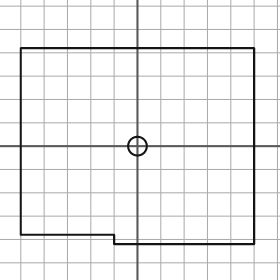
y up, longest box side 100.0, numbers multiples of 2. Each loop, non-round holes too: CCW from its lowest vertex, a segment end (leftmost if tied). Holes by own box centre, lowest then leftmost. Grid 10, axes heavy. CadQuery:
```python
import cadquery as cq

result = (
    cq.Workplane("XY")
    .moveTo(-10.0, -42.0)
    .lineTo(50.0, -42.0)
    .lineTo(50.0, 42.0)
    .lineTo(-50.0, 42.0)
    .lineTo(-50.0, -38.0)
    .lineTo(-10.0, -38.0)
    .close()
    .moveTo(0.0, 0.0)
    .circle(4.0)
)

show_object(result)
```